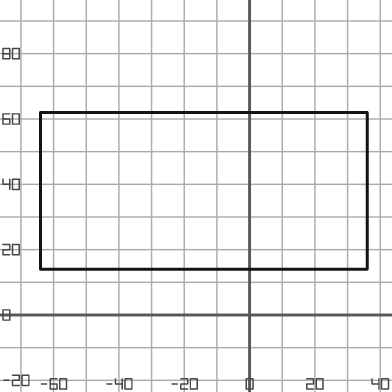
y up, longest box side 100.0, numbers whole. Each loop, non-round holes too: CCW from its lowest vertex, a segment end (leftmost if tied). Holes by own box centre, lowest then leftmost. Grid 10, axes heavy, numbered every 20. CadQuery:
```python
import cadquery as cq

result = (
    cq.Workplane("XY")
    .moveTo(-64.0, 14.0)
    .lineTo(36.0, 14.0)
    .lineTo(36.0, 62.0)
    .lineTo(-64.0, 62.0)
    .close()
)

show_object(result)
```